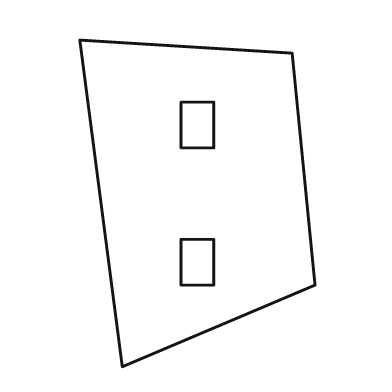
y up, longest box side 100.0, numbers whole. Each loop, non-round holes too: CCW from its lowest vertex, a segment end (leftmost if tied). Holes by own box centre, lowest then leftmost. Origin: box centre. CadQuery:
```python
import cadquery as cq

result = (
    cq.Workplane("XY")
    .moveTo(-23.0, -50.0)
    .lineTo(36.0, -25.0)
    .lineTo(29.0, 46.0)
    .lineTo(-36.0, 50.0)
    .close()
    .moveTo(-5.0, -25.0)
    .lineTo(5.0, -25.0)
    .lineTo(5.0, -11.0)
    .lineTo(-5.0, -11.0)
    .close()
    .moveTo(-5.0, 17.0)
    .lineTo(5.0, 17.0)
    .lineTo(5.0, 31.0)
    .lineTo(-5.0, 31.0)
    .close()
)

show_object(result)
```